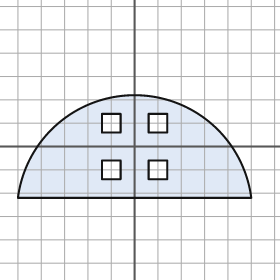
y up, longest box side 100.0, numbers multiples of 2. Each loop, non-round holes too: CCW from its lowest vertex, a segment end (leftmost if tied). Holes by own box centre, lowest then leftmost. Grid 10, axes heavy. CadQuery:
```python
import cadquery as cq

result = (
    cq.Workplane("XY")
    .moveTo(-50.0, -22.0)
    .lineTo(50.0, -22.0)
    .threePointArc((0.0, 22.0), (-50.0, -22.0))
    .close()
    .moveTo(-14.0, -14.0)
    .lineTo(-6.0, -14.0)
    .lineTo(-6.0, -6.0)
    .lineTo(-14.0, -6.0)
    .close()
    .moveTo(6.0, -14.0)
    .lineTo(14.0, -14.0)
    .lineTo(14.0, -6.0)
    .lineTo(6.0, -6.0)
    .close()
    .moveTo(-14.0, 6.0)
    .lineTo(-6.0, 6.0)
    .lineTo(-6.0, 14.0)
    .lineTo(-14.0, 14.0)
    .close()
    .moveTo(6.0, 6.0)
    .lineTo(14.0, 6.0)
    .lineTo(14.0, 14.0)
    .lineTo(6.0, 14.0)
    .close()
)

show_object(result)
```